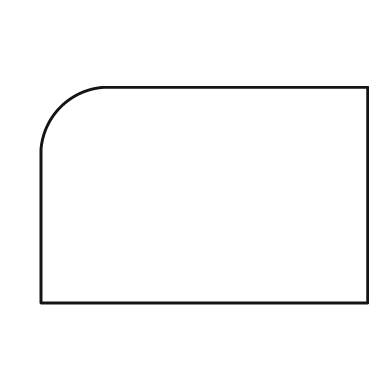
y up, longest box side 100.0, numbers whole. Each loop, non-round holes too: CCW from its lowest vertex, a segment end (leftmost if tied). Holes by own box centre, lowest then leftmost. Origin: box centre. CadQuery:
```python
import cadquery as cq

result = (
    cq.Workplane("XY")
    .moveTo(-50.0, -33.0)
    .lineTo(50.0, -33.0)
    .lineTo(50.0, 33.0)
    .lineTo(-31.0, 33.0)
    .threePointArc((-44.0, 27.0), (-50.0, 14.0))
    .close()
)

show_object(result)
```